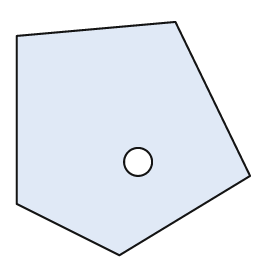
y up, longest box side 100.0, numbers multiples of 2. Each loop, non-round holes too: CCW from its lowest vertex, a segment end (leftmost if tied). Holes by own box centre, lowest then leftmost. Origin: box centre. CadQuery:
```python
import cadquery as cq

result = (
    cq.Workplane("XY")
    .moveTo(-6.0, -50.0)
    .lineTo(50.0, -16.0)
    .lineTo(18.0, 50.0)
    .lineTo(-50.0, 44.0)
    .lineTo(-50.0, -28.0)
    .close()
    .moveTo(2.0, -10.0)
    .circle(6.0)
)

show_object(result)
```